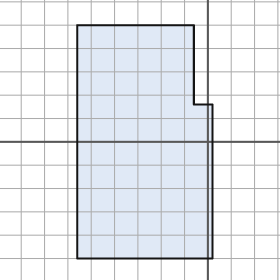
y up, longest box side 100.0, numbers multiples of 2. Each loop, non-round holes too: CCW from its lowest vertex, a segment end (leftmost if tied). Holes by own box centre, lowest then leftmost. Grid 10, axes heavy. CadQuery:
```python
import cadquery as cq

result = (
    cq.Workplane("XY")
    .moveTo(-56.0, -50.0)
    .lineTo(2.0, -50.0)
    .lineTo(2.0, 16.0)
    .lineTo(-6.0, 16.0)
    .lineTo(-6.0, 50.0)
    .lineTo(-56.0, 50.0)
    .close()
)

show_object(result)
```